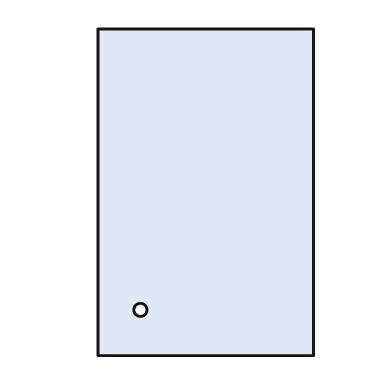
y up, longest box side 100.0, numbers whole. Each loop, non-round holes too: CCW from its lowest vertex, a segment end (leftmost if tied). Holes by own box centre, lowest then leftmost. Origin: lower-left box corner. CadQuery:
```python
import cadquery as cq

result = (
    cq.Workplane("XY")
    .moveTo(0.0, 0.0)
    .lineTo(66.0, 0.0)
    .lineTo(66.0, 100.0)
    .lineTo(0.0, 100.0)
    .close()
    .moveTo(13.0, 14.0)
    .circle(2.0)
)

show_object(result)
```